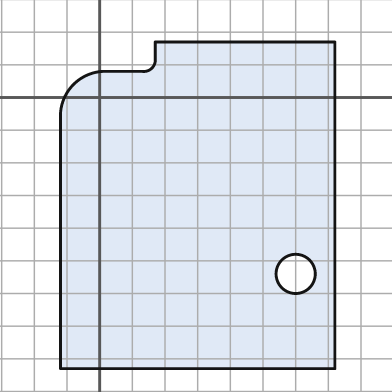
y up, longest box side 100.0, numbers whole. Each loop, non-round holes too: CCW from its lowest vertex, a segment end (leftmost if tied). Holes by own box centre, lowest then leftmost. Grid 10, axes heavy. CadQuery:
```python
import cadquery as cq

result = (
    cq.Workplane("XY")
    .moveTo(-12.0, -83.0)
    .lineTo(72.0, -83.0)
    .lineTo(72.0, 17.0)
    .lineTo(17.0, 17.0)
    .lineTo(17.0, 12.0)
    .threePointArc((16.0, 9.0), (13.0, 8.0))
    .lineTo(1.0, 8.0)
    .threePointArc((-8.0, 4.0), (-12.0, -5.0))
    .close()
    .moveTo(60.0, -54.0)
    .circle(6.0)
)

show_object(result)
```